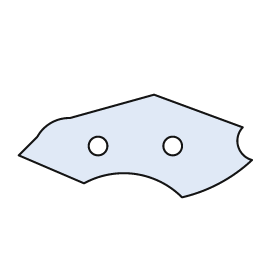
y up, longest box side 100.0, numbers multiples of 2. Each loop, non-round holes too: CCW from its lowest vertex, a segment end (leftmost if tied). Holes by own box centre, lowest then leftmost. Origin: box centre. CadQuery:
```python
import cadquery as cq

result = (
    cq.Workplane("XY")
    .moveTo(20.0, -22.0)
    .threePointArc((36.0, -16.0), (50.0, -6.0))
    .threePointArc((44.0, 0.0), (46.0, 8.0))
    .lineTo(8.0, 22.0)
    .lineTo(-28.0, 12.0)
    .threePointArc((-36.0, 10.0), (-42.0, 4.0))
    .lineTo(-50.0, -4.0)
    .lineTo(-22.0, -16.0)
    .threePointArc((0.0, -12.0), (20.0, -22.0))
    .close()
    .moveTo(-16.0, 0.0)
    .circle(4.0)
    .moveTo(16.0, 0.0)
    .circle(4.0)
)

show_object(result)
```